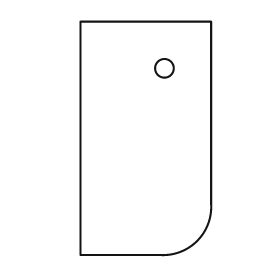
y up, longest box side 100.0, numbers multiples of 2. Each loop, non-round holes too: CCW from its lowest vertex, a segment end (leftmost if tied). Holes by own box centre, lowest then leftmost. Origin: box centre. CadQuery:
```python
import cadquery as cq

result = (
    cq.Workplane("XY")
    .moveTo(-28.0, -50.0)
    .lineTo(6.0, -50.0)
    .threePointArc((22.0, -44.0), (28.0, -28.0))
    .lineTo(28.0, 50.0)
    .lineTo(-28.0, 50.0)
    .close()
    .moveTo(8.0, 30.0)
    .circle(4.0)
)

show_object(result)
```